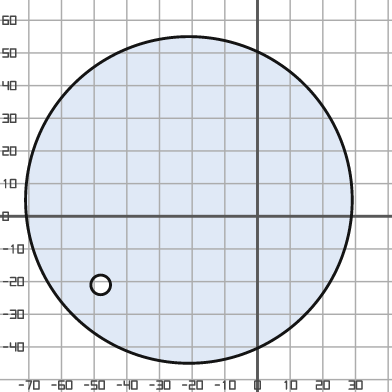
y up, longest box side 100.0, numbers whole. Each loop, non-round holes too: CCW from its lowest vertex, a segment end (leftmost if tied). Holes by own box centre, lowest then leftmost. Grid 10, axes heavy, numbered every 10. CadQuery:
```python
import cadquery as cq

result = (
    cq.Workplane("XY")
    .moveTo(-21.0, 5.0)
    .circle(50.0)
    .moveTo(-48.0, -21.0)
    .circle(3.0)
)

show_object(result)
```